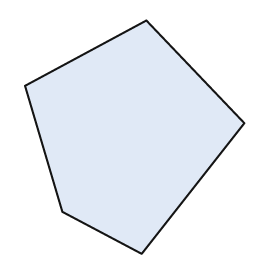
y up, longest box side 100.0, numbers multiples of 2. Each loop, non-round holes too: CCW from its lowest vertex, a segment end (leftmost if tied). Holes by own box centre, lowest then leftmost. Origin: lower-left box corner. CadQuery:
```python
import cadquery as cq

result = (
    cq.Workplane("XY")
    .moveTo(50.0, 0.0)
    .lineTo(94.0, 56.0)
    .lineTo(52.0, 100.0)
    .lineTo(0.0, 72.0)
    .lineTo(16.0, 18.0)
    .close()
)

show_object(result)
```